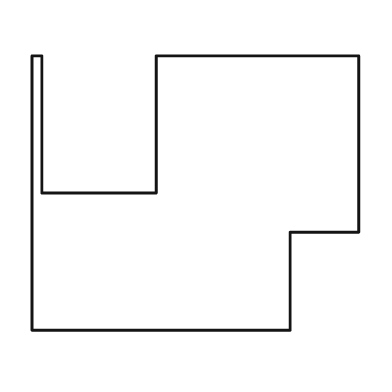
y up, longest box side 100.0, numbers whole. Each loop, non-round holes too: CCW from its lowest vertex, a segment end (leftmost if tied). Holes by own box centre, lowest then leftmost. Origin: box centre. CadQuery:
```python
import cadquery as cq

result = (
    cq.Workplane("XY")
    .moveTo(-50.0, -42.0)
    .lineTo(29.0, -42.0)
    .lineTo(29.0, -12.0)
    .lineTo(50.0, -12.0)
    .lineTo(50.0, 42.0)
    .lineTo(-12.0, 42.0)
    .lineTo(-12.0, 0.0)
    .lineTo(-47.0, 0.0)
    .lineTo(-47.0, 42.0)
    .lineTo(-50.0, 42.0)
    .close()
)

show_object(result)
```